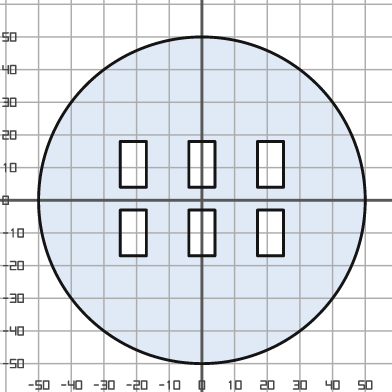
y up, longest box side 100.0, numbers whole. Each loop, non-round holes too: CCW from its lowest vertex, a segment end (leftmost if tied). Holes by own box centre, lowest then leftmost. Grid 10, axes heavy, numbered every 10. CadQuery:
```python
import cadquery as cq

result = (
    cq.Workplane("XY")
    .moveTo(0.0, 0.0)
    .circle(50.0)
    .moveTo(-25.0, -17.0)
    .lineTo(-17.0, -17.0)
    .lineTo(-17.0, -3.0)
    .lineTo(-25.0, -3.0)
    .close()
    .moveTo(-4.0, -17.0)
    .lineTo(4.0, -17.0)
    .lineTo(4.0, -3.0)
    .lineTo(-4.0, -3.0)
    .close()
    .moveTo(17.0, -17.0)
    .lineTo(25.0, -17.0)
    .lineTo(25.0, -3.0)
    .lineTo(17.0, -3.0)
    .close()
    .moveTo(-25.0, 4.0)
    .lineTo(-17.0, 4.0)
    .lineTo(-17.0, 18.0)
    .lineTo(-25.0, 18.0)
    .close()
    .moveTo(-4.0, 4.0)
    .lineTo(4.0, 4.0)
    .lineTo(4.0, 18.0)
    .lineTo(-4.0, 18.0)
    .close()
    .moveTo(17.0, 4.0)
    .lineTo(25.0, 4.0)
    .lineTo(25.0, 18.0)
    .lineTo(17.0, 18.0)
    .close()
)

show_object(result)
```